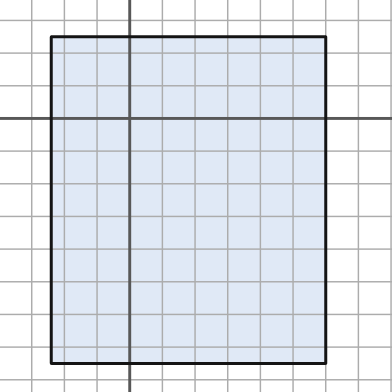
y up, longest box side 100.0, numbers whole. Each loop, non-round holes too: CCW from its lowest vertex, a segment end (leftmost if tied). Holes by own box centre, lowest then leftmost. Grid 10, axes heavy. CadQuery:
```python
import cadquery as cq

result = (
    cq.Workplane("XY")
    .moveTo(-24.0, -75.0)
    .lineTo(60.0, -75.0)
    .lineTo(60.0, 25.0)
    .lineTo(-24.0, 25.0)
    .close()
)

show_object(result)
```